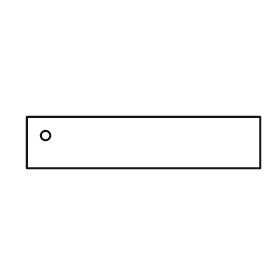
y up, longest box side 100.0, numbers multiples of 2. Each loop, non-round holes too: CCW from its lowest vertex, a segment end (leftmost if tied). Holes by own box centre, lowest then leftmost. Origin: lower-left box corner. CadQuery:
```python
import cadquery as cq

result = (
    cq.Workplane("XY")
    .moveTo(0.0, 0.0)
    .lineTo(100.0, 0.0)
    .lineTo(100.0, 22.0)
    .lineTo(0.0, 22.0)
    .close()
    .moveTo(8.0, 14.0)
    .circle(2.0)
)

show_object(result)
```